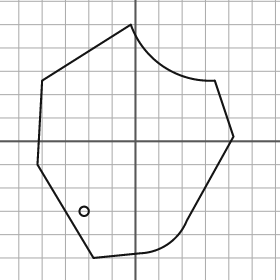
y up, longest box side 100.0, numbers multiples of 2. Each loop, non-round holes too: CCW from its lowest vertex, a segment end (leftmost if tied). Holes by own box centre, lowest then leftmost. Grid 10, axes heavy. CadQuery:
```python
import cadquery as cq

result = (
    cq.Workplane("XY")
    .moveTo(-18.0, -50.0)
    .lineTo(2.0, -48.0)
    .threePointArc((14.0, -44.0), (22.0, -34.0))
    .lineTo(42.0, 2.0)
    .lineTo(34.0, 26.0)
    .threePointArc((12.0, 32.0), (-2.0, 50.0))
    .lineTo(-40.0, 26.0)
    .lineTo(-42.0, -10.0)
    .close()
    .moveTo(-22.0, -30.0)
    .circle(2.0)
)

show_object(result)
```